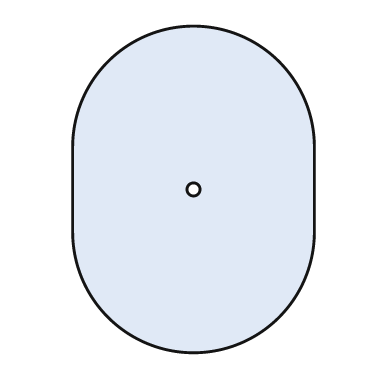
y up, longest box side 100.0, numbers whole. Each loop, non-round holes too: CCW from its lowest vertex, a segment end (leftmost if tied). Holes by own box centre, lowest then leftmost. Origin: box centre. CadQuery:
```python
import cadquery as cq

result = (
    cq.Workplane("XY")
    .moveTo(-37.0, -13.0)
    .threePointArc((0.0, -50.0), (37.0, -13.0))
    .lineTo(37.0, 13.0)
    .threePointArc((0.0, 50.0), (-37.0, 13.0))
    .close()
    .moveTo(0.0, 0.0)
    .circle(2.0)
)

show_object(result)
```